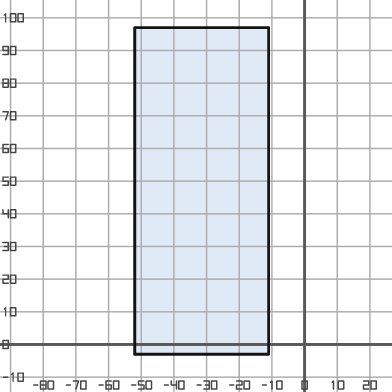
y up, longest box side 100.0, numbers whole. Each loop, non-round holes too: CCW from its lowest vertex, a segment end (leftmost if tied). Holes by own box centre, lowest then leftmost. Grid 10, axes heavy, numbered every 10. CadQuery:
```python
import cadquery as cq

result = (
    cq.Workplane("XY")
    .moveTo(-52.0, -3.0)
    .lineTo(-11.0, -3.0)
    .lineTo(-11.0, 97.0)
    .lineTo(-52.0, 97.0)
    .close()
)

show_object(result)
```